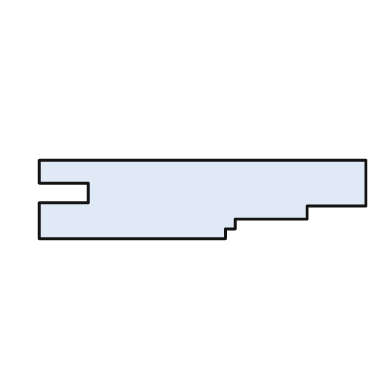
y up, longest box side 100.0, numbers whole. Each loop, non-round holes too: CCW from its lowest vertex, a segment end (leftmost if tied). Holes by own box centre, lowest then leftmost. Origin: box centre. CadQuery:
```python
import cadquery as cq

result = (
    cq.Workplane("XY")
    .moveTo(-50.0, -12.0)
    .lineTo(7.0, -12.0)
    .lineTo(7.0, -9.0)
    .lineTo(10.0, -9.0)
    .lineTo(10.0, -6.0)
    .lineTo(32.0, -6.0)
    .lineTo(32.0, -2.0)
    .lineTo(50.0, -2.0)
    .lineTo(50.0, 12.0)
    .lineTo(-50.0, 12.0)
    .lineTo(-50.0, 5.0)
    .lineTo(-35.0, 5.0)
    .lineTo(-35.0, -1.0)
    .lineTo(-50.0, -1.0)
    .close()
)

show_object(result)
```